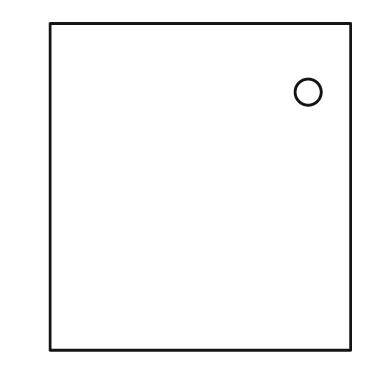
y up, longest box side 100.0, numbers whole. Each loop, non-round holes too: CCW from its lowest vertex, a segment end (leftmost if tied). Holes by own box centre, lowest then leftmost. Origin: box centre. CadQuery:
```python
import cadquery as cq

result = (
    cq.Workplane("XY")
    .moveTo(-46.0, -50.0)
    .lineTo(46.0, -50.0)
    .lineTo(46.0, 50.0)
    .lineTo(-46.0, 50.0)
    .close()
    .moveTo(33.0, 29.0)
    .circle(4.0)
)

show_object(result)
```